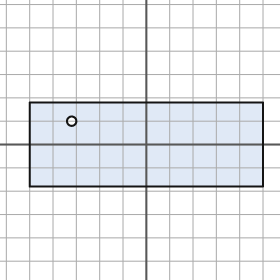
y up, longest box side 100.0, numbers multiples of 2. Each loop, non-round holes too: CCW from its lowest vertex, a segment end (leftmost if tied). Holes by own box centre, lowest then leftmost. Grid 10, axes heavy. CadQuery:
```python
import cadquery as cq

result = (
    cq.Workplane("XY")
    .moveTo(-50.0, -18.0)
    .lineTo(50.0, -18.0)
    .lineTo(50.0, 18.0)
    .lineTo(-50.0, 18.0)
    .close()
    .moveTo(-32.0, 10.0)
    .circle(2.0)
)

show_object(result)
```